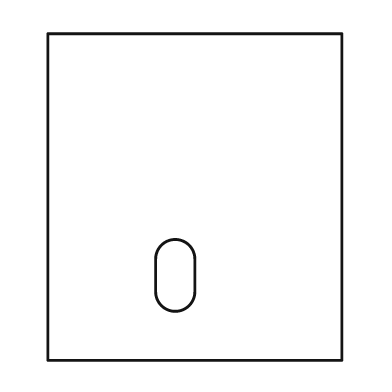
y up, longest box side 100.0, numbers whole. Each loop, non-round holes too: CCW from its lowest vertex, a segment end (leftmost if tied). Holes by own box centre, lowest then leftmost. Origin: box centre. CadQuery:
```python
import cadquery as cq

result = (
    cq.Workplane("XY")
    .moveTo(-45.0, -50.0)
    .lineTo(45.0, -50.0)
    .lineTo(45.0, 50.0)
    .lineTo(-45.0, 50.0)
    .close()
    .moveTo(-12.0, -29.0)
    .threePointArc((-6.0, -35.0), (0.0, -29.0))
    .lineTo(0.0, -19.0)
    .threePointArc((-6.0, -13.0), (-12.0, -19.0))
    .close()
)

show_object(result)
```